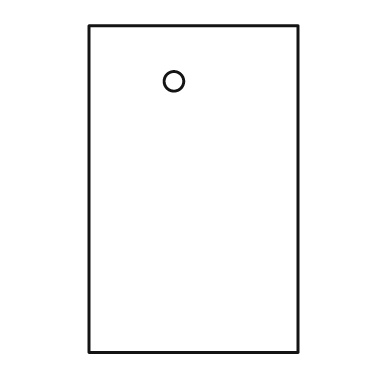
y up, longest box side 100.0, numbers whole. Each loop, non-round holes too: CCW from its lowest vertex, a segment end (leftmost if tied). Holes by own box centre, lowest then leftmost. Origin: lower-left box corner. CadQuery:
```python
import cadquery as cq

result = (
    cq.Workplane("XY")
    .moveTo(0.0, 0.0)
    .lineTo(64.0, 0.0)
    .lineTo(64.0, 100.0)
    .lineTo(0.0, 100.0)
    .close()
    .moveTo(26.0, 83.0)
    .circle(3.0)
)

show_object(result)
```